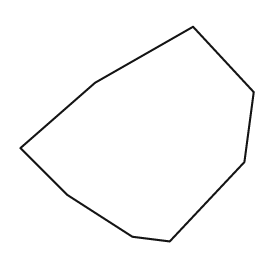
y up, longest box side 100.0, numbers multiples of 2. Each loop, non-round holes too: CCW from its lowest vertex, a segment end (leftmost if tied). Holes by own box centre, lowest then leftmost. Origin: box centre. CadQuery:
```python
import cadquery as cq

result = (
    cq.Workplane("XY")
    .moveTo(14.0, -46.0)
    .lineTo(46.0, -12.0)
    .lineTo(50.0, 18.0)
    .lineTo(24.0, 46.0)
    .lineTo(-18.0, 22.0)
    .lineTo(-50.0, -6.0)
    .lineTo(-30.0, -26.0)
    .lineTo(-2.0, -44.0)
    .close()
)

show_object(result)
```